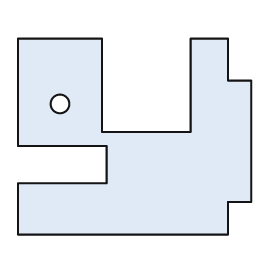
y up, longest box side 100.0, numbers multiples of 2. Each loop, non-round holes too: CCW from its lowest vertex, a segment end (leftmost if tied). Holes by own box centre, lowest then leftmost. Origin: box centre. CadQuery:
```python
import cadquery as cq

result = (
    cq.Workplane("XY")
    .moveTo(-50.0, -42.0)
    .lineTo(40.0, -42.0)
    .lineTo(40.0, -28.0)
    .lineTo(50.0, -28.0)
    .lineTo(50.0, 24.0)
    .lineTo(40.0, 24.0)
    .lineTo(40.0, 42.0)
    .lineTo(24.0, 42.0)
    .lineTo(24.0, 2.0)
    .lineTo(-14.0, 2.0)
    .lineTo(-14.0, 42.0)
    .lineTo(-50.0, 42.0)
    .lineTo(-50.0, -4.0)
    .lineTo(-12.0, -4.0)
    .lineTo(-12.0, -20.0)
    .lineTo(-50.0, -20.0)
    .close()
    .moveTo(-32.0, 14.0)
    .circle(4.0)
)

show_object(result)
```